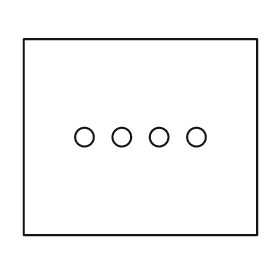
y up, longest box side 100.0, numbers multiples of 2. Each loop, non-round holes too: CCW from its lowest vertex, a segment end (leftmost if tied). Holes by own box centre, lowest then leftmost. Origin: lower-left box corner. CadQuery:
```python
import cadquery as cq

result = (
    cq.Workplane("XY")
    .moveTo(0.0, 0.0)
    .lineTo(100.0, 0.0)
    .lineTo(100.0, 84.0)
    .lineTo(0.0, 84.0)
    .close()
    .moveTo(26.0, 42.0)
    .circle(4.0)
    .moveTo(42.0, 42.0)
    .circle(4.0)
    .moveTo(58.0, 42.0)
    .circle(4.0)
    .moveTo(74.0, 42.0)
    .circle(4.0)
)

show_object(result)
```